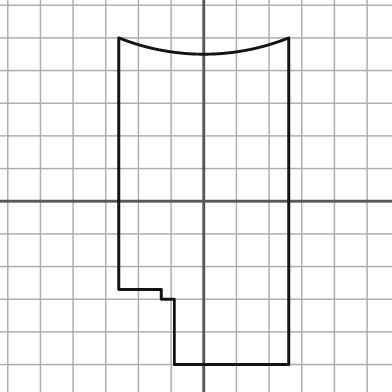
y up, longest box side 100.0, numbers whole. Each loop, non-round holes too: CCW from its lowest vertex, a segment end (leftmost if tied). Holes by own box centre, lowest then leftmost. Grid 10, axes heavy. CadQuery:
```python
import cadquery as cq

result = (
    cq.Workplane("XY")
    .moveTo(-9.0, -50.0)
    .lineTo(26.0, -50.0)
    .lineTo(26.0, 50.0)
    .threePointArc((0.0, 45.0), (-26.0, 50.0))
    .lineTo(-26.0, -27.0)
    .lineTo(-13.0, -27.0)
    .lineTo(-13.0, -30.0)
    .lineTo(-9.0, -30.0)
    .close()
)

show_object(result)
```